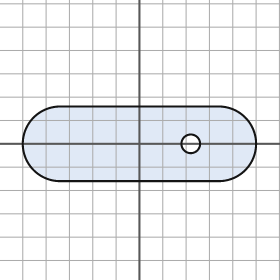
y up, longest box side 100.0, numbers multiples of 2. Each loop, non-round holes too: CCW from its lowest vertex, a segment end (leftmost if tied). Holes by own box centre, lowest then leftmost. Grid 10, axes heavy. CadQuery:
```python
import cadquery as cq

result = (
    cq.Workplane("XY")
    .moveTo(-34.0, -16.0)
    .lineTo(34.0, -16.0)
    .threePointArc((50.0, 0.0), (34.0, 16.0))
    .lineTo(-34.0, 16.0)
    .threePointArc((-50.0, 0.0), (-34.0, -16.0))
    .close()
    .moveTo(22.0, 0.0)
    .circle(4.0)
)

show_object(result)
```